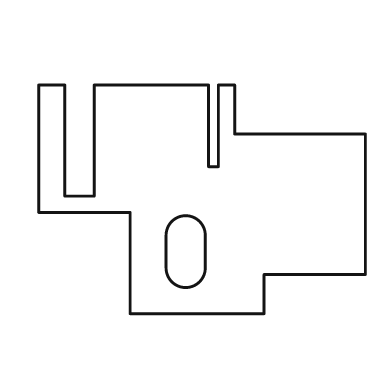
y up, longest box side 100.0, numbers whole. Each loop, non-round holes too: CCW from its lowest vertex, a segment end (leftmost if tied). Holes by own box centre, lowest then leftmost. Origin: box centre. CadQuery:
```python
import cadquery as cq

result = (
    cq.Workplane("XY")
    .moveTo(-22.0, -35.0)
    .lineTo(19.0, -35.0)
    .lineTo(19.0, -23.0)
    .lineTo(50.0, -23.0)
    .lineTo(50.0, 20.0)
    .lineTo(10.0, 20.0)
    .lineTo(10.0, 35.0)
    .lineTo(5.0, 35.0)
    .lineTo(5.0, 10.0)
    .lineTo(2.0, 10.0)
    .lineTo(2.0, 35.0)
    .lineTo(-33.0, 35.0)
    .lineTo(-33.0, 1.0)
    .lineTo(-42.0, 1.0)
    .lineTo(-42.0, 35.0)
    .lineTo(-50.0, 35.0)
    .lineTo(-50.0, -4.0)
    .lineTo(-22.0, -4.0)
    .close()
    .moveTo(-11.0, -21.0)
    .threePointArc((-5.0, -27.0), (1.0, -21.0))
    .lineTo(1.0, -11.0)
    .threePointArc((-5.0, -5.0), (-11.0, -11.0))
    .close()
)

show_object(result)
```